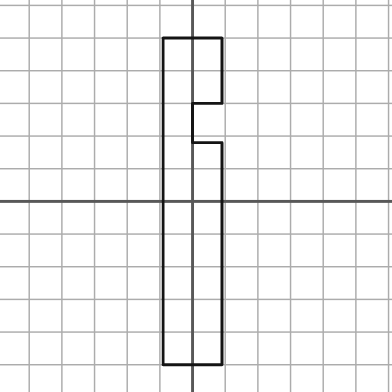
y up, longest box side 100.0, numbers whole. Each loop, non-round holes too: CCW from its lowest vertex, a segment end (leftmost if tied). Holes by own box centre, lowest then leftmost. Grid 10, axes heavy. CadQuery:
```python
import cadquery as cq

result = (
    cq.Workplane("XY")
    .moveTo(-9.0, -50.0)
    .lineTo(9.0, -50.0)
    .lineTo(9.0, 18.0)
    .lineTo(0.0, 18.0)
    .lineTo(0.0, 30.0)
    .lineTo(9.0, 30.0)
    .lineTo(9.0, 50.0)
    .lineTo(-9.0, 50.0)
    .close()
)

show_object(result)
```